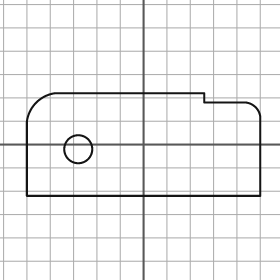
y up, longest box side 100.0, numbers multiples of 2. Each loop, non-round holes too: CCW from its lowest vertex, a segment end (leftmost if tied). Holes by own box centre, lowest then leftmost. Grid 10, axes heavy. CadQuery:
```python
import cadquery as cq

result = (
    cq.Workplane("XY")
    .moveTo(-50.0, -22.0)
    .lineTo(50.0, -22.0)
    .lineTo(50.0, 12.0)
    .threePointArc((48.0, 16.0), (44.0, 18.0))
    .lineTo(26.0, 18.0)
    .lineTo(26.0, 22.0)
    .lineTo(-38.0, 22.0)
    .threePointArc((-46.0, 18.0), (-50.0, 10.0))
    .close()
    .moveTo(-28.0, -2.0)
    .circle(6.0)
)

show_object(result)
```